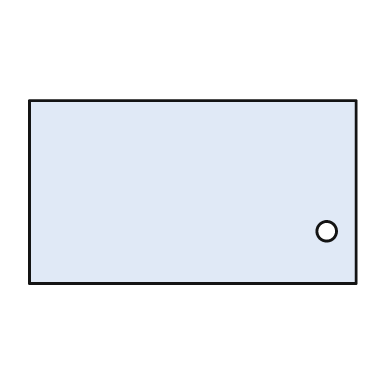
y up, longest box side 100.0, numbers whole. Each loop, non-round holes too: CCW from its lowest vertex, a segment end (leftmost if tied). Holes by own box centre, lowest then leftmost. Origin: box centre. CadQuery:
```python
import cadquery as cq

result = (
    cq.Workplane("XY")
    .moveTo(-50.0, -28.0)
    .lineTo(50.0, -28.0)
    .lineTo(50.0, 28.0)
    .lineTo(-50.0, 28.0)
    .close()
    .moveTo(41.0, -12.0)
    .circle(3.0)
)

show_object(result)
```